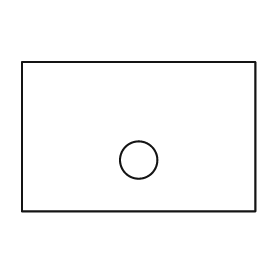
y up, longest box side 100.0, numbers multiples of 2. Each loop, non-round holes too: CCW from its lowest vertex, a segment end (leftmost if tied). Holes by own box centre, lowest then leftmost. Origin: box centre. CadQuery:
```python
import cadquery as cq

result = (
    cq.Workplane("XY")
    .moveTo(-50.0, -32.0)
    .lineTo(50.0, -32.0)
    .lineTo(50.0, 32.0)
    .lineTo(-50.0, 32.0)
    .close()
    .moveTo(0.0, -10.0)
    .circle(8.0)
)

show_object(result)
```